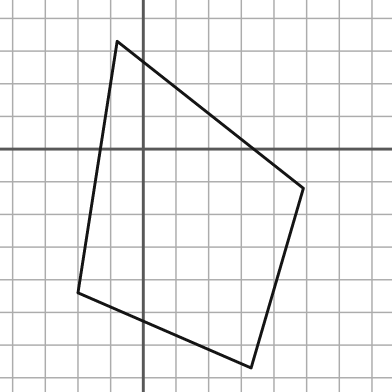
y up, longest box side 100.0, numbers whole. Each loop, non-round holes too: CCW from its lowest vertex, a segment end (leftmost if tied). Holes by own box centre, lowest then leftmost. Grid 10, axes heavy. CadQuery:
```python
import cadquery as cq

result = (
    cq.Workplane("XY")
    .moveTo(33.0, -67.0)
    .lineTo(49.0, -12.0)
    .lineTo(-8.0, 33.0)
    .lineTo(-20.0, -44.0)
    .close()
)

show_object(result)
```